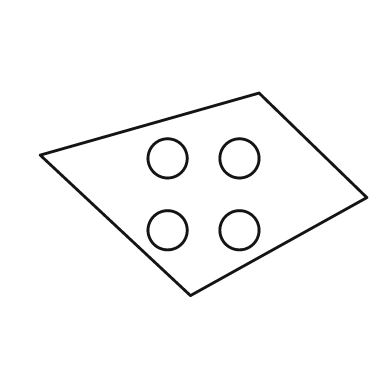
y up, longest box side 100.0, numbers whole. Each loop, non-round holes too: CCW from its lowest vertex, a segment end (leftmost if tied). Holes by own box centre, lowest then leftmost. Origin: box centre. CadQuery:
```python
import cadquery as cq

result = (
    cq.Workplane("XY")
    .moveTo(-4.0, -31.0)
    .lineTo(50.0, -1.0)
    .lineTo(17.0, 31.0)
    .lineTo(-50.0, 12.0)
    .close()
    .moveTo(-11.0, -11.0)
    .circle(6.0)
    .moveTo(11.0, -11.0)
    .circle(6.0)
    .moveTo(-11.0, 11.0)
    .circle(6.0)
    .moveTo(11.0, 11.0)
    .circle(6.0)
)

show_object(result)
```